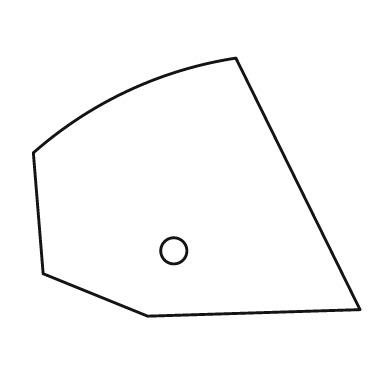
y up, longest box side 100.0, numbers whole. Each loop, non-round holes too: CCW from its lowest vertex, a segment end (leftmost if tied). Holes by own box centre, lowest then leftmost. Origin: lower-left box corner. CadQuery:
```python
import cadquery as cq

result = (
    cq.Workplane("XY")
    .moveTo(35.0, 0.0)
    .lineTo(100.0, 2.0)
    .lineTo(62.0, 79.0)
    .threePointArc((29.0, 69.0), (0.0, 50.0))
    .lineTo(3.0, 13.0)
    .close()
    .moveTo(43.0, 20.0)
    .circle(4.0)
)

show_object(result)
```